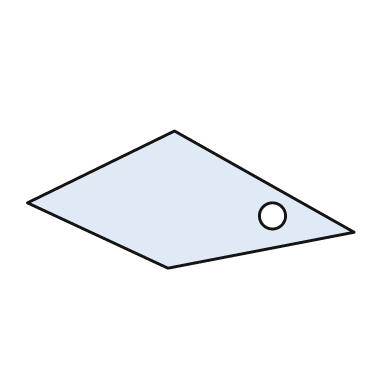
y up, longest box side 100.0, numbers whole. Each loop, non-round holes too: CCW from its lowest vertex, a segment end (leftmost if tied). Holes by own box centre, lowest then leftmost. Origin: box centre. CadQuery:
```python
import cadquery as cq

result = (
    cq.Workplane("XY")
    .moveTo(-7.0, -21.0)
    .lineTo(50.0, -10.0)
    .lineTo(-5.0, 21.0)
    .lineTo(-50.0, -1.0)
    .close()
    .moveTo(25.0, -5.0)
    .circle(4.0)
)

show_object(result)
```